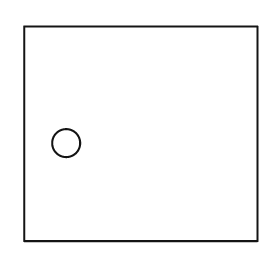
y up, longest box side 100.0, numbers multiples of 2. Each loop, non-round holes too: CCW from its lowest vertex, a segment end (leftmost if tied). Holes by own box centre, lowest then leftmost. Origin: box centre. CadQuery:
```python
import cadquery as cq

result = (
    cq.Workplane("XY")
    .moveTo(-50.0, -46.0)
    .lineTo(50.0, -46.0)
    .lineTo(50.0, 46.0)
    .lineTo(-50.0, 46.0)
    .close()
    .moveTo(-32.0, -4.0)
    .circle(6.0)
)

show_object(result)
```